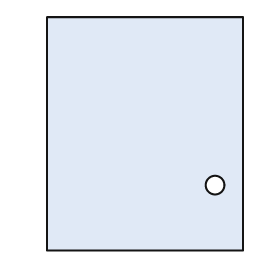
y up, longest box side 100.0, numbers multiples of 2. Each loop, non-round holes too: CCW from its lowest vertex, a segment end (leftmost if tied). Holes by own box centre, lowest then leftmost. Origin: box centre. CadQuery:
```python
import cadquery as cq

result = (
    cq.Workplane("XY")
    .moveTo(-42.0, -50.0)
    .lineTo(42.0, -50.0)
    .lineTo(42.0, 50.0)
    .lineTo(-42.0, 50.0)
    .close()
    .moveTo(30.0, -22.0)
    .circle(4.0)
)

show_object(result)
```